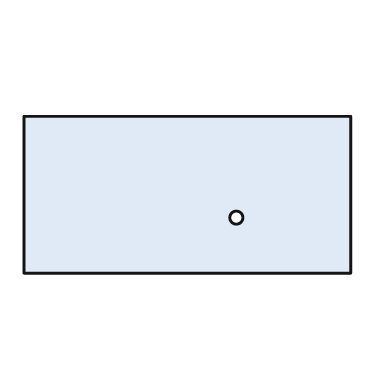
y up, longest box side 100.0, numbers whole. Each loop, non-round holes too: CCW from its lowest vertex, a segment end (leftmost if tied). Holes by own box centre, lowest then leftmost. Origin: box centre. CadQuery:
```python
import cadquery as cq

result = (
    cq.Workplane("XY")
    .moveTo(-50.0, -24.0)
    .lineTo(50.0, -24.0)
    .lineTo(50.0, 24.0)
    .lineTo(-50.0, 24.0)
    .close()
    .moveTo(15.0, -7.0)
    .circle(2.0)
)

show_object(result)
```